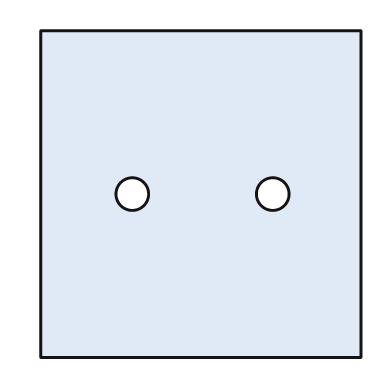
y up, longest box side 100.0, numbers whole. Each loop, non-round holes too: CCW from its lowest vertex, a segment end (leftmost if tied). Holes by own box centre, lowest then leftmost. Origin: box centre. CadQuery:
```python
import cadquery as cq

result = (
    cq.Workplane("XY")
    .moveTo(-49.0, -50.0)
    .lineTo(49.0, -50.0)
    .lineTo(49.0, 50.0)
    .lineTo(-49.0, 50.0)
    .close()
    .moveTo(-21.0, 0.0)
    .circle(5.0)
    .moveTo(22.0, 0.0)
    .circle(5.0)
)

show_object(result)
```